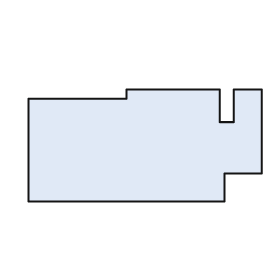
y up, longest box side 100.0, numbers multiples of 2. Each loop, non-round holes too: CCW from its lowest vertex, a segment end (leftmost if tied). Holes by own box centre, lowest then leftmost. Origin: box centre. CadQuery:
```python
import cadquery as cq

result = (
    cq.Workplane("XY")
    .moveTo(-50.0, -24.0)
    .lineTo(34.0, -24.0)
    .lineTo(34.0, -12.0)
    .lineTo(50.0, -12.0)
    .lineTo(50.0, 24.0)
    .lineTo(38.0, 24.0)
    .lineTo(38.0, 10.0)
    .lineTo(32.0, 10.0)
    .lineTo(32.0, 24.0)
    .lineTo(-8.0, 24.0)
    .lineTo(-8.0, 20.0)
    .lineTo(-50.0, 20.0)
    .close()
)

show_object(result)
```